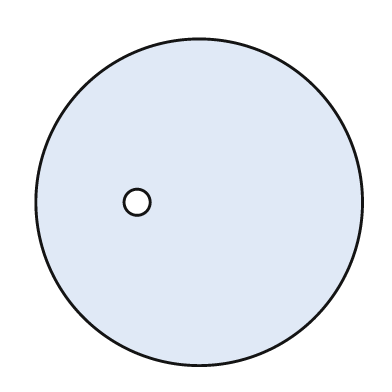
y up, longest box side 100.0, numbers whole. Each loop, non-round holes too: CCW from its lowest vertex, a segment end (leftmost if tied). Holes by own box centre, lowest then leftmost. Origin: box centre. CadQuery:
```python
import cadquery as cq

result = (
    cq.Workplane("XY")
    .moveTo(0.0, 0.0)
    .circle(50.0)
    .moveTo(-19.0, 0.0)
    .circle(4.0)
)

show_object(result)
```